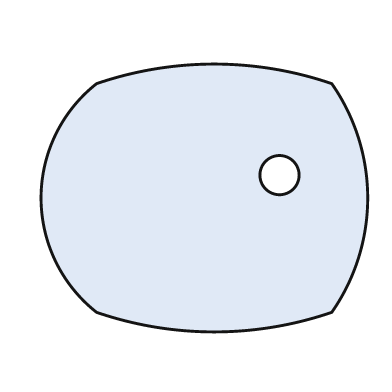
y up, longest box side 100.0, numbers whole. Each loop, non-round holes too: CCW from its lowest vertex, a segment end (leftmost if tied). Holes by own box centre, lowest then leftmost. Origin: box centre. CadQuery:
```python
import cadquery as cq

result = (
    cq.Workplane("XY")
    .moveTo(-33.0, -35.0)
    .threePointArc((3.0, -41.0), (39.0, -35.0))
    .threePointArc((50.0, 0.0), (39.0, 35.0))
    .threePointArc((3.0, 41.0), (-33.0, 35.0))
    .threePointArc((-50.0, 0.0), (-33.0, -35.0))
    .close()
    .moveTo(23.0, 7.0)
    .circle(6.0)
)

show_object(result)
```